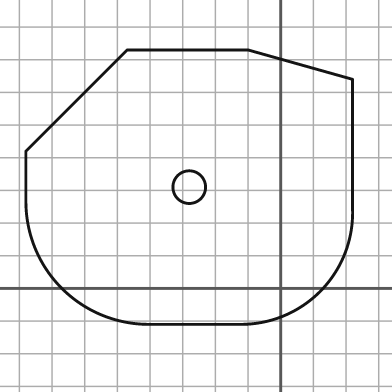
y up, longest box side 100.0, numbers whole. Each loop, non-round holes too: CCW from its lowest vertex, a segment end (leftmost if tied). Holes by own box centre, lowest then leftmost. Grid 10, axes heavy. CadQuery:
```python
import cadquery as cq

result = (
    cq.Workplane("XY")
    .moveTo(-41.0, -11.0)
    .lineTo(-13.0, -11.0)
    .threePointArc((12.0, -1.0), (22.0, 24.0))
    .lineTo(22.0, 64.0)
    .lineTo(-10.0, 73.0)
    .lineTo(-47.0, 73.0)
    .lineTo(-78.0, 42.0)
    .lineTo(-78.0, 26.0)
    .threePointArc((-67.0, 0.0), (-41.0, -11.0))
    .close()
    .moveTo(-28.0, 31.0)
    .circle(5.0)
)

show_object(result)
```